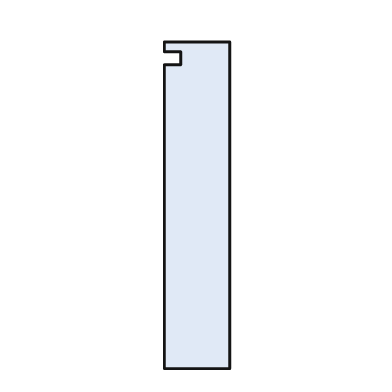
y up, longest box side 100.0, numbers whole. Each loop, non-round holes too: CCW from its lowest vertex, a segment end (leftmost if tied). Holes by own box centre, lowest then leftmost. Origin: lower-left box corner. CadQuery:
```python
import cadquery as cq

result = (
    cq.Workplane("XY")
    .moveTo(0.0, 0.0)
    .lineTo(20.0, 0.0)
    .lineTo(20.0, 100.0)
    .lineTo(0.0, 100.0)
    .lineTo(0.0, 97.0)
    .lineTo(5.0, 97.0)
    .lineTo(5.0, 93.0)
    .lineTo(0.0, 93.0)
    .close()
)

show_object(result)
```